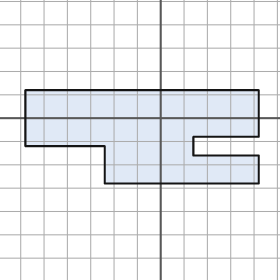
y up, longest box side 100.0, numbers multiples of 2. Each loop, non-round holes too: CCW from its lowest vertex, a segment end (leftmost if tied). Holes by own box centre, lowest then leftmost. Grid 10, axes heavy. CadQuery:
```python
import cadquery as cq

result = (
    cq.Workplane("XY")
    .moveTo(-24.0, -28.0)
    .lineTo(42.0, -28.0)
    .lineTo(42.0, -16.0)
    .lineTo(14.0, -16.0)
    .lineTo(14.0, -8.0)
    .lineTo(42.0, -8.0)
    .lineTo(42.0, 12.0)
    .lineTo(-58.0, 12.0)
    .lineTo(-58.0, -12.0)
    .lineTo(-24.0, -12.0)
    .close()
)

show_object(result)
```